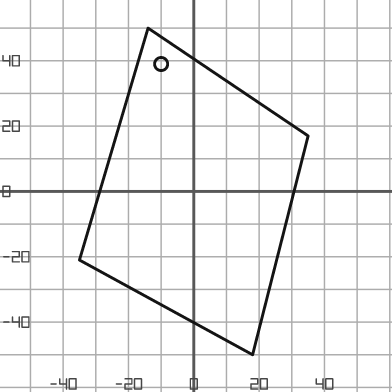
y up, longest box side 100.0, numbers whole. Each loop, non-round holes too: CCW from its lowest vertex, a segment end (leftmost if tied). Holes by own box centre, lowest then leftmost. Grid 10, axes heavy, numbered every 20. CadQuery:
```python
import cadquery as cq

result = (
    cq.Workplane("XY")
    .moveTo(18.0, -50.0)
    .lineTo(35.0, 17.0)
    .lineTo(-14.0, 50.0)
    .lineTo(-35.0, -21.0)
    .close()
    .moveTo(-10.0, 39.0)
    .circle(2.0)
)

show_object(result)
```